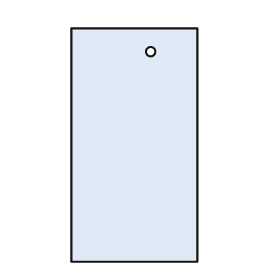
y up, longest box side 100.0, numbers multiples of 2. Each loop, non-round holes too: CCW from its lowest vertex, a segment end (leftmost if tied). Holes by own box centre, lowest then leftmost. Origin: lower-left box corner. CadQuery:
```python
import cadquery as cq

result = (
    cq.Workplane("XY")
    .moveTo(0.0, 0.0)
    .lineTo(54.0, 0.0)
    .lineTo(54.0, 100.0)
    .lineTo(0.0, 100.0)
    .close()
    .moveTo(34.0, 90.0)
    .circle(2.0)
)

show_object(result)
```